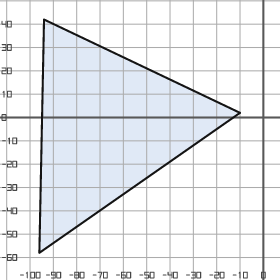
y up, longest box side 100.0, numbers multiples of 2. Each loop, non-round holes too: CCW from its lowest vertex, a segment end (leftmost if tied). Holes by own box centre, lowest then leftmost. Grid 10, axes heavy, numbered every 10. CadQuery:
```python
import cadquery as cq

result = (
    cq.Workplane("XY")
    .moveTo(-96.0, -58.0)
    .lineTo(-10.0, 2.0)
    .lineTo(-94.0, 42.0)
    .close()
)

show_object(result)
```